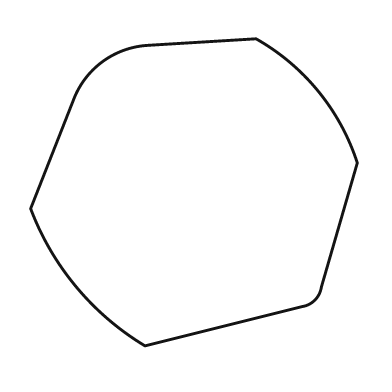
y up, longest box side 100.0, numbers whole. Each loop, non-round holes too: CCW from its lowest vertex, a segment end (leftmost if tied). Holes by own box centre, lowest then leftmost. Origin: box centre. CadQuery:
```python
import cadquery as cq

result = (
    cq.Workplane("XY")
    .moveTo(-15.0, -47.0)
    .lineTo(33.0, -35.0)
    .threePointArc((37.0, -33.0), (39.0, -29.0))
    .lineTo(50.0, 9.0)
    .threePointArc((38.0, 31.0), (19.0, 47.0))
    .lineTo(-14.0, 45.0)
    .threePointArc((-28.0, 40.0), (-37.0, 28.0))
    .lineTo(-50.0, -5.0)
    .threePointArc((-36.0, -29.0), (-15.0, -47.0))
    .close()
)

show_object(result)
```